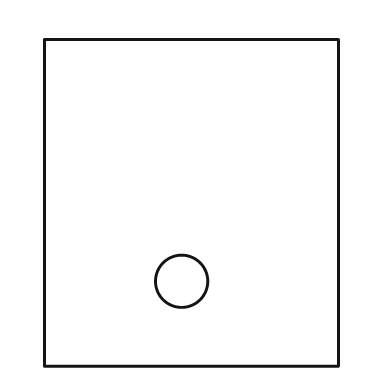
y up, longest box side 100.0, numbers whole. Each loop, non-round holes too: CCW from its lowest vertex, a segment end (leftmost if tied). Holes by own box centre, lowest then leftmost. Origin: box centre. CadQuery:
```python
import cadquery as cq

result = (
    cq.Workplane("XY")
    .moveTo(-45.0, -50.0)
    .lineTo(45.0, -50.0)
    .lineTo(45.0, 50.0)
    .lineTo(-45.0, 50.0)
    .close()
    .moveTo(-3.0, -24.0)
    .circle(8.0)
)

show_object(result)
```